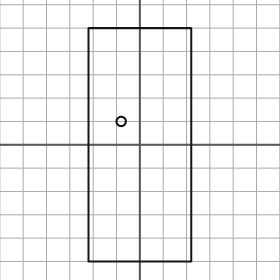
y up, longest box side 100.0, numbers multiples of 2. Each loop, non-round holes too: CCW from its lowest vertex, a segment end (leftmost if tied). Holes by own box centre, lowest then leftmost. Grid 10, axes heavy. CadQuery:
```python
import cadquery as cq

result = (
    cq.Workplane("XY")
    .moveTo(-22.0, -50.0)
    .lineTo(22.0, -50.0)
    .lineTo(22.0, 50.0)
    .lineTo(-22.0, 50.0)
    .close()
    .moveTo(-8.0, 10.0)
    .circle(2.0)
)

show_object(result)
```